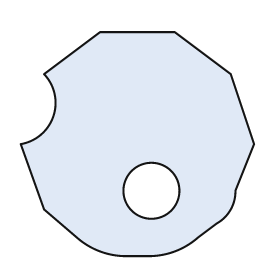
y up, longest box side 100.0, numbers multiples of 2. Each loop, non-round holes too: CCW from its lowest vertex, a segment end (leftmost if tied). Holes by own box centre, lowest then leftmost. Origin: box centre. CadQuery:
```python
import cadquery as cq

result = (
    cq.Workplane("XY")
    .moveTo(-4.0, -48.0)
    .lineTo(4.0, -48.0)
    .threePointArc((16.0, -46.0), (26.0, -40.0))
    .lineTo(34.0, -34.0)
    .threePointArc((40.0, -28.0), (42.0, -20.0))
    .lineTo(50.0, 0.0)
    .lineTo(40.0, 30.0)
    .lineTo(16.0, 48.0)
    .lineTo(-16.0, 48.0)
    .lineTo(-40.0, 30.0)
    .threePointArc((-36.0, 12.0), (-50.0, 0.0))
    .lineTo(-40.0, -28.0)
    .lineTo(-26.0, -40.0)
    .threePointArc((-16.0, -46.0), (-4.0, -48.0))
    .close()
    .moveTo(6.0, -20.0)
    .circle(12.0)
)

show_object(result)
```